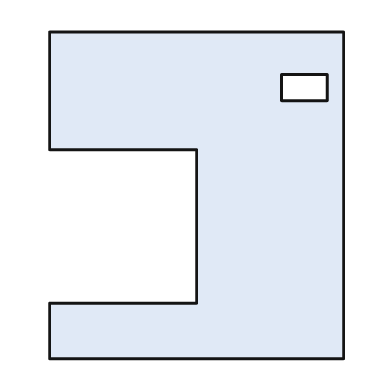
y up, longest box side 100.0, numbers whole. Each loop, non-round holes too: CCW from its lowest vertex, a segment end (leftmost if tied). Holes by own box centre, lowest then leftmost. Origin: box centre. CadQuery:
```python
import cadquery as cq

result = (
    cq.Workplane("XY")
    .moveTo(-45.0, -50.0)
    .lineTo(45.0, -50.0)
    .lineTo(45.0, 50.0)
    .lineTo(-45.0, 50.0)
    .lineTo(-45.0, 14.0)
    .lineTo(0.0, 14.0)
    .lineTo(0.0, -33.0)
    .lineTo(-45.0, -33.0)
    .close()
    .moveTo(26.0, 29.0)
    .lineTo(40.0, 29.0)
    .lineTo(40.0, 37.0)
    .lineTo(26.0, 37.0)
    .close()
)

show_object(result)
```